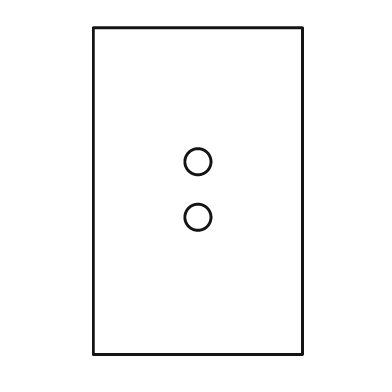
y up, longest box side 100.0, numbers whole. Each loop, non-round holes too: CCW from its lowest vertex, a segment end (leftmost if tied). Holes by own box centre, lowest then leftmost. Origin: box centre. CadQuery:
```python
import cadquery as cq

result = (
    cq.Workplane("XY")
    .moveTo(-32.0, -50.0)
    .lineTo(32.0, -50.0)
    .lineTo(32.0, 50.0)
    .lineTo(-32.0, 50.0)
    .close()
    .moveTo(0.0, -8.0)
    .circle(4.0)
    .moveTo(0.0, 9.0)
    .circle(4.0)
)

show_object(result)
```